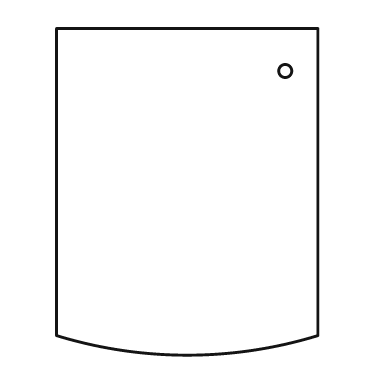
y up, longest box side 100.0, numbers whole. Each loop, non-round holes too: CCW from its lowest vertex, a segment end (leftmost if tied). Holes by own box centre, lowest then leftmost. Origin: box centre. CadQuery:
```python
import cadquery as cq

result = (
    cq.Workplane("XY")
    .moveTo(-40.0, -44.0)
    .threePointArc((0.0, -50.0), (40.0, -44.0))
    .lineTo(40.0, 50.0)
    .lineTo(-40.0, 50.0)
    .close()
    .moveTo(30.0, 37.0)
    .circle(2.0)
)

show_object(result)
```